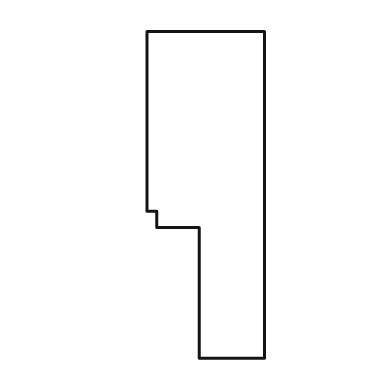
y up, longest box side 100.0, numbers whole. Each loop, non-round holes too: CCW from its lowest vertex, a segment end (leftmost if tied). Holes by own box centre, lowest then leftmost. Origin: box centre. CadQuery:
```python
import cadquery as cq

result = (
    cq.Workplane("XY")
    .moveTo(-2.0, -50.0)
    .lineTo(18.0, -50.0)
    .lineTo(18.0, 50.0)
    .lineTo(-18.0, 50.0)
    .lineTo(-18.0, -5.0)
    .lineTo(-15.0, -5.0)
    .lineTo(-15.0, -10.0)
    .lineTo(-2.0, -10.0)
    .close()
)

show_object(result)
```